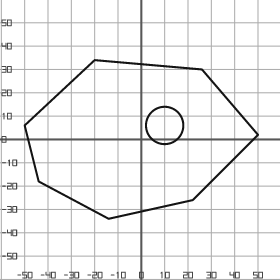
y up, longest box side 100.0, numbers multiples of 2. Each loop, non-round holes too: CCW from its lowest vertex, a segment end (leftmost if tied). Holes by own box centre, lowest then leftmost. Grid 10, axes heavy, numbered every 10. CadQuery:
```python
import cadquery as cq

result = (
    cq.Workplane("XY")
    .moveTo(-14.0, -34.0)
    .lineTo(22.0, -26.0)
    .lineTo(50.0, 2.0)
    .lineTo(26.0, 30.0)
    .lineTo(-20.0, 34.0)
    .lineTo(-50.0, 6.0)
    .lineTo(-44.0, -18.0)
    .close()
    .moveTo(10.0, 6.0)
    .circle(8.0)
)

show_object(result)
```